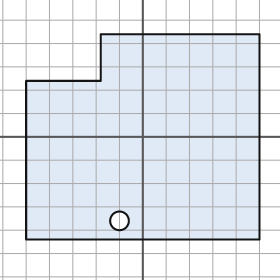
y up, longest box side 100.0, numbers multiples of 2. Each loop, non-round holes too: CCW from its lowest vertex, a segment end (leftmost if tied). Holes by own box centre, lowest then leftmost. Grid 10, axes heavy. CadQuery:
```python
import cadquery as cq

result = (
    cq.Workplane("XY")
    .moveTo(-50.0, -44.0)
    .lineTo(50.0, -44.0)
    .lineTo(50.0, 44.0)
    .lineTo(-18.0, 44.0)
    .lineTo(-18.0, 24.0)
    .lineTo(-50.0, 24.0)
    .close()
    .moveTo(-10.0, -36.0)
    .circle(4.0)
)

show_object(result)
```